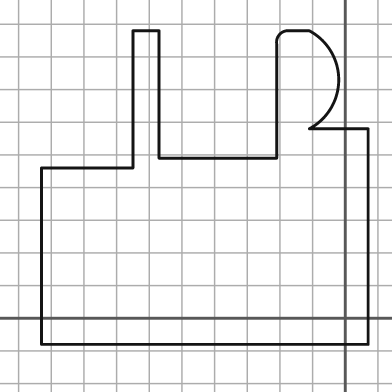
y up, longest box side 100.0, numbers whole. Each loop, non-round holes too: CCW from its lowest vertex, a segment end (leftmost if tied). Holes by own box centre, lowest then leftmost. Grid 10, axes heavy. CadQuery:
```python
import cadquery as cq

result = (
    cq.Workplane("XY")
    .moveTo(-93.0, -8.0)
    .lineTo(7.0, -8.0)
    .lineTo(7.0, 58.0)
    .lineTo(-11.0, 58.0)
    .threePointArc((-2.0, 73.0), (-11.0, 88.0))
    .lineTo(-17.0, 88.0)
    .threePointArc((-20.0, 87.0), (-21.0, 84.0))
    .lineTo(-21.0, 49.0)
    .lineTo(-57.0, 49.0)
    .lineTo(-57.0, 88.0)
    .lineTo(-65.0, 88.0)
    .lineTo(-65.0, 46.0)
    .lineTo(-93.0, 46.0)
    .close()
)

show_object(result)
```